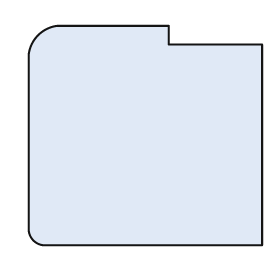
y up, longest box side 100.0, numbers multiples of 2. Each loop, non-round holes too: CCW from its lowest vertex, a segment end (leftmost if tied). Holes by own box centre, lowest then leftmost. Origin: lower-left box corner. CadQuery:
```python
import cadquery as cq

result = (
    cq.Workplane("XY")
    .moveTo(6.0, 0.0)
    .lineTo(100.0, 0.0)
    .lineTo(100.0, 86.0)
    .lineTo(60.0, 86.0)
    .lineTo(60.0, 94.0)
    .lineTo(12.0, 94.0)
    .threePointArc((4.0, 90.0), (0.0, 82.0))
    .lineTo(0.0, 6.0)
    .threePointArc((2.0, 2.0), (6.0, 0.0))
    .close()
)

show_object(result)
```